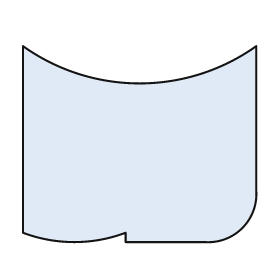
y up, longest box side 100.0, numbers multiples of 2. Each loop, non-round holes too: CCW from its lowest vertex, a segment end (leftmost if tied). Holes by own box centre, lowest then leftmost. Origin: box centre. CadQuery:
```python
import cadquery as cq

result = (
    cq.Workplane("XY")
    .moveTo(-6.0, -42.0)
    .lineTo(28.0, -42.0)
    .threePointArc((44.0, -36.0), (50.0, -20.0))
    .lineTo(50.0, 42.0)
    .threePointArc((0.0, 26.0), (-50.0, 42.0))
    .lineTo(-50.0, -38.0)
    .threePointArc((-28.0, -42.0), (-6.0, -38.0))
    .close()
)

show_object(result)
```